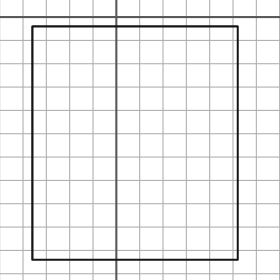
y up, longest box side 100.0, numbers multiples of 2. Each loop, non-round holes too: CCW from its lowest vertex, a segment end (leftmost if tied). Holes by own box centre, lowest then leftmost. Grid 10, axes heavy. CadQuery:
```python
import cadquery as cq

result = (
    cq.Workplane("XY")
    .moveTo(-36.0, -104.0)
    .lineTo(52.0, -104.0)
    .lineTo(52.0, -4.0)
    .lineTo(-36.0, -4.0)
    .close()
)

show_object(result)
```